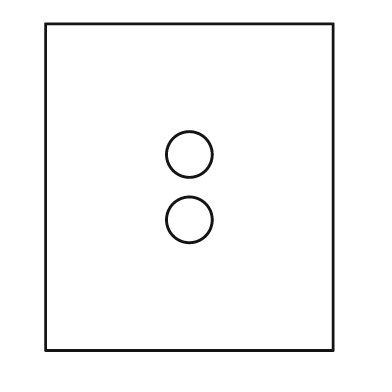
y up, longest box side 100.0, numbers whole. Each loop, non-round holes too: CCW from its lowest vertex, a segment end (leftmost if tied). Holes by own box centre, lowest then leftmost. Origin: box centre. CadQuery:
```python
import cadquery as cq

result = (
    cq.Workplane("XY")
    .moveTo(-44.0, -50.0)
    .lineTo(44.0, -50.0)
    .lineTo(44.0, 50.0)
    .lineTo(-44.0, 50.0)
    .close()
    .moveTo(0.0, -10.0)
    .circle(7.0)
    .moveTo(0.0, 10.0)
    .circle(7.0)
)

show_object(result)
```